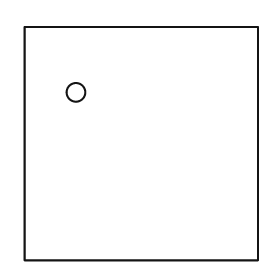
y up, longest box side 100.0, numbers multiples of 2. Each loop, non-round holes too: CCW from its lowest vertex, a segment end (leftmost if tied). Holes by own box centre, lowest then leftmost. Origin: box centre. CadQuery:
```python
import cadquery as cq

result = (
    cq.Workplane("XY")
    .moveTo(-50.0, -50.0)
    .lineTo(50.0, -50.0)
    .lineTo(50.0, 50.0)
    .lineTo(-50.0, 50.0)
    .close()
    .moveTo(-28.0, 22.0)
    .circle(4.0)
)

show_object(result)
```